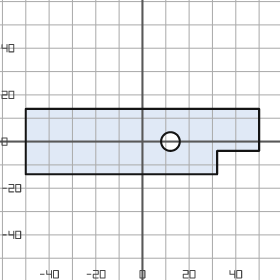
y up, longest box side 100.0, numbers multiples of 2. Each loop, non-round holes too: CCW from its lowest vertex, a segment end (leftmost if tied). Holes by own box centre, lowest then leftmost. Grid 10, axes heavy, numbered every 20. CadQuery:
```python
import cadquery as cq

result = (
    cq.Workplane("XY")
    .moveTo(-50.0, -14.0)
    .lineTo(32.0, -14.0)
    .lineTo(32.0, -4.0)
    .lineTo(50.0, -4.0)
    .lineTo(50.0, 14.0)
    .lineTo(-50.0, 14.0)
    .close()
    .moveTo(12.0, 0.0)
    .circle(4.0)
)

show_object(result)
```